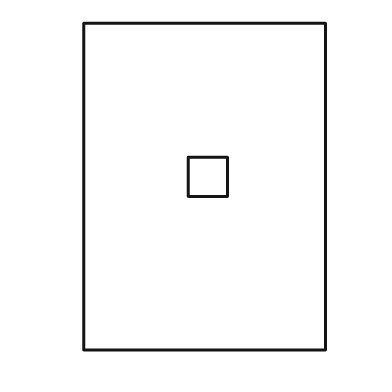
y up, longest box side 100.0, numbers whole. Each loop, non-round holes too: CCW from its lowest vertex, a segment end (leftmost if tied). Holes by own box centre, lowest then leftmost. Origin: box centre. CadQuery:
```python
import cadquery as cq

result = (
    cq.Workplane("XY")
    .moveTo(-37.0, -50.0)
    .lineTo(37.0, -50.0)
    .lineTo(37.0, 50.0)
    .lineTo(-37.0, 50.0)
    .close()
    .moveTo(-5.0, -3.0)
    .lineTo(7.0, -3.0)
    .lineTo(7.0, 9.0)
    .lineTo(-5.0, 9.0)
    .close()
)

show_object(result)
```